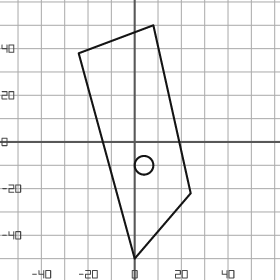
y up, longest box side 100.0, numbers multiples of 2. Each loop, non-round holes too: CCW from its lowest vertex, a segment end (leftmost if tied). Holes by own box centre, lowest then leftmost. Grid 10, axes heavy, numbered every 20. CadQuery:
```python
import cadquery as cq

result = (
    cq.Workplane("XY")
    .moveTo(0.0, -50.0)
    .lineTo(24.0, -22.0)
    .lineTo(8.0, 50.0)
    .lineTo(-24.0, 38.0)
    .close()
    .moveTo(4.0, -10.0)
    .circle(4.0)
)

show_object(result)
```